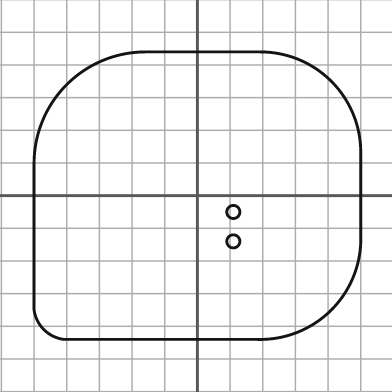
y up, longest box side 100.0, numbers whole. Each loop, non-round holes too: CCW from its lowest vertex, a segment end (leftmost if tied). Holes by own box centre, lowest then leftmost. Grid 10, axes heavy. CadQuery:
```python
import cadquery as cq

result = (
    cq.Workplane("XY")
    .moveTo(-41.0, -44.0)
    .lineTo(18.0, -44.0)
    .threePointArc((41.0, -35.0), (50.0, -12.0))
    .lineTo(50.0, 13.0)
    .threePointArc((41.0, 35.0), (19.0, 44.0))
    .lineTo(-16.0, 44.0)
    .threePointArc((-40.0, 34.0), (-50.0, 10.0))
    .lineTo(-50.0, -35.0)
    .threePointArc((-47.0, -41.0), (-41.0, -44.0))
    .close()
    .moveTo(11.0, -14.0)
    .circle(2.0)
    .moveTo(11.0, -5.0)
    .circle(2.0)
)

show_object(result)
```